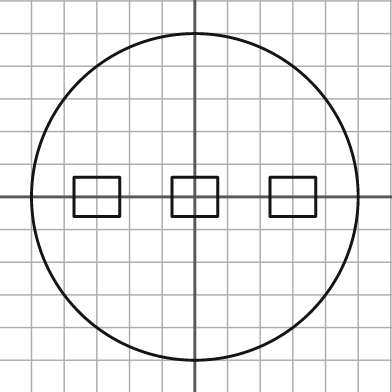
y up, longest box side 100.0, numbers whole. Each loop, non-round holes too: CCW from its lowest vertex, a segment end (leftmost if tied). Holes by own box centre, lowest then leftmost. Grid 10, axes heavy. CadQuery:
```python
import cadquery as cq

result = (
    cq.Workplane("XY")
    .moveTo(0.0, 0.0)
    .circle(50.0)
    .moveTo(-37.0, -6.0)
    .lineTo(-23.0, -6.0)
    .lineTo(-23.0, 6.0)
    .lineTo(-37.0, 6.0)
    .close()
    .moveTo(-7.0, -6.0)
    .lineTo(7.0, -6.0)
    .lineTo(7.0, 6.0)
    .lineTo(-7.0, 6.0)
    .close()
    .moveTo(23.0, -6.0)
    .lineTo(37.0, -6.0)
    .lineTo(37.0, 6.0)
    .lineTo(23.0, 6.0)
    .close()
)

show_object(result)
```